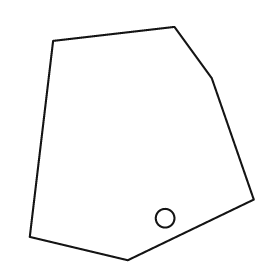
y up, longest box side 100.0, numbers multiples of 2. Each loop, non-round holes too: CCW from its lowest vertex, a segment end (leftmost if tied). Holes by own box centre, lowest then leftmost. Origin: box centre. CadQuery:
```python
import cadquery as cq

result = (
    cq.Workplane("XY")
    .moveTo(-6.0, -50.0)
    .lineTo(48.0, -24.0)
    .lineTo(30.0, 28.0)
    .lineTo(14.0, 50.0)
    .lineTo(-38.0, 44.0)
    .lineTo(-48.0, -40.0)
    .close()
    .moveTo(10.0, -32.0)
    .circle(4.0)
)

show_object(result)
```